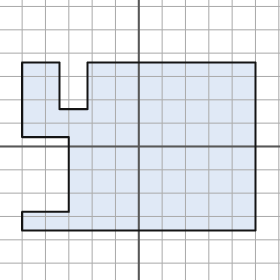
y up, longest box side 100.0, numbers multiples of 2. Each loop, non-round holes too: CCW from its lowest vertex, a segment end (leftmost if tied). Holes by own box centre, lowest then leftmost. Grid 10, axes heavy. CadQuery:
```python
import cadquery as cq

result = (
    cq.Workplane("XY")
    .moveTo(-50.0, -36.0)
    .lineTo(50.0, -36.0)
    .lineTo(50.0, 36.0)
    .lineTo(-22.0, 36.0)
    .lineTo(-22.0, 16.0)
    .lineTo(-34.0, 16.0)
    .lineTo(-34.0, 36.0)
    .lineTo(-50.0, 36.0)
    .lineTo(-50.0, 4.0)
    .lineTo(-30.0, 4.0)
    .lineTo(-30.0, -28.0)
    .lineTo(-50.0, -28.0)
    .close()
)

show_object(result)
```